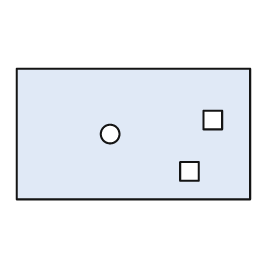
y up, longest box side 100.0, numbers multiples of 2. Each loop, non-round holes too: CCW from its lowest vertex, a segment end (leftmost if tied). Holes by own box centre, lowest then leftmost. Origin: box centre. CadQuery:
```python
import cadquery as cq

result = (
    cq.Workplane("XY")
    .moveTo(-50.0, -28.0)
    .lineTo(50.0, -28.0)
    .lineTo(50.0, 28.0)
    .lineTo(-50.0, 28.0)
    .close()
    .moveTo(20.0, -20.0)
    .lineTo(28.0, -20.0)
    .lineTo(28.0, -12.0)
    .lineTo(20.0, -12.0)
    .close()
    .moveTo(-10.0, 0.0)
    .circle(4.0)
    .moveTo(30.0, 2.0)
    .lineTo(38.0, 2.0)
    .lineTo(38.0, 10.0)
    .lineTo(30.0, 10.0)
    .close()
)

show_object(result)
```